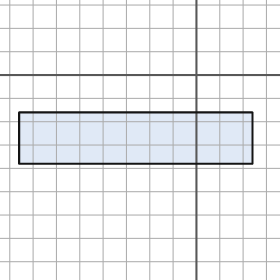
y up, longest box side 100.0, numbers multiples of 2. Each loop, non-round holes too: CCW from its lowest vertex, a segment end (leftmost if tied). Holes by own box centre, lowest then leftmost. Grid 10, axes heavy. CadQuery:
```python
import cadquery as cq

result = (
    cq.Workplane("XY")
    .moveTo(-76.0, -38.0)
    .lineTo(24.0, -38.0)
    .lineTo(24.0, -16.0)
    .lineTo(-76.0, -16.0)
    .close()
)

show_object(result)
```